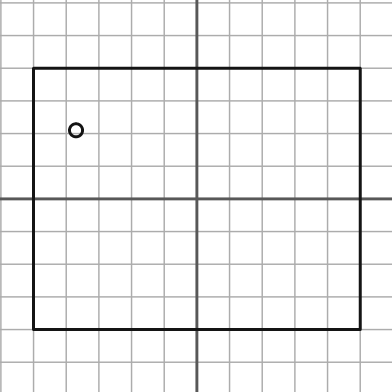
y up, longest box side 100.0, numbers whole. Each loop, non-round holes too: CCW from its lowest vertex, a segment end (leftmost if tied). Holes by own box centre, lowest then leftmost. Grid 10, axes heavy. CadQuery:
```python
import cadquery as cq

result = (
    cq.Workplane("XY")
    .moveTo(-50.0, -40.0)
    .lineTo(50.0, -40.0)
    .lineTo(50.0, 40.0)
    .lineTo(-50.0, 40.0)
    .close()
    .moveTo(-37.0, 21.0)
    .circle(2.0)
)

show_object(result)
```